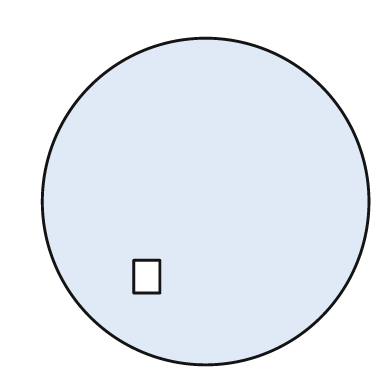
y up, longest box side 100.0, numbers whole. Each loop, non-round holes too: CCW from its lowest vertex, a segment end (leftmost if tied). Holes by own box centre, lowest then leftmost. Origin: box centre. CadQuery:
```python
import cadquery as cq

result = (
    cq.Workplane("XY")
    .moveTo(0.0, 0.0)
    .circle(50.0)
    .moveTo(-22.0, -28.0)
    .lineTo(-14.0, -28.0)
    .lineTo(-14.0, -18.0)
    .lineTo(-22.0, -18.0)
    .close()
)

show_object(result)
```